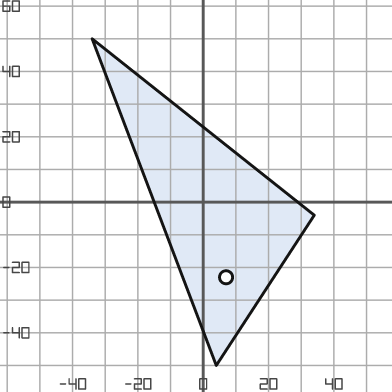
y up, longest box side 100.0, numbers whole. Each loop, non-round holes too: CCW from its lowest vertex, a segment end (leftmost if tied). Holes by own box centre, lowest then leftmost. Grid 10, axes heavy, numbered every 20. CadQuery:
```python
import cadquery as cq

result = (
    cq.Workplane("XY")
    .moveTo(4.0, -50.0)
    .lineTo(34.0, -4.0)
    .lineTo(-34.0, 50.0)
    .close()
    .moveTo(7.0, -23.0)
    .circle(2.0)
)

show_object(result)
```